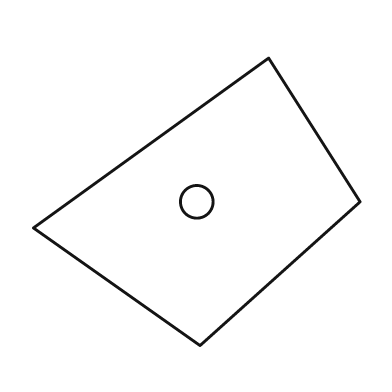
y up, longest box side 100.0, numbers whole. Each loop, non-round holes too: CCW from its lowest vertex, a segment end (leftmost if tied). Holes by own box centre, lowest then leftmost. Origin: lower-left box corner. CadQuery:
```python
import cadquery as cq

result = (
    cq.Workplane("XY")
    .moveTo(51.0, 0.0)
    .lineTo(100.0, 44.0)
    .lineTo(72.0, 88.0)
    .lineTo(0.0, 36.0)
    .close()
    .moveTo(50.0, 44.0)
    .circle(5.0)
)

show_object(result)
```